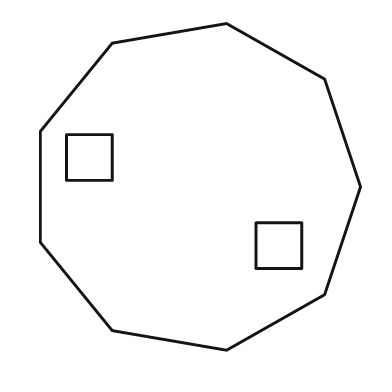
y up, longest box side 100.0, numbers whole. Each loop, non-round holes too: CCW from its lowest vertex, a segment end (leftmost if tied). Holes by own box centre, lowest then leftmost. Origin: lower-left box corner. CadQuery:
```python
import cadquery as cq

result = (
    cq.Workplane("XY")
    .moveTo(57.0, 0.0)
    .lineTo(87.0, 17.0)
    .lineTo(98.0, 50.0)
    .lineTo(87.0, 83.0)
    .lineTo(57.0, 100.0)
    .lineTo(22.0, 94.0)
    .lineTo(0.0, 67.0)
    .lineTo(0.0, 33.0)
    .lineTo(22.0, 6.0)
    .close()
    .moveTo(66.0, 25.0)
    .lineTo(80.0, 25.0)
    .lineTo(80.0, 39.0)
    .lineTo(66.0, 39.0)
    .close()
    .moveTo(8.0, 52.0)
    .lineTo(22.0, 52.0)
    .lineTo(22.0, 66.0)
    .lineTo(8.0, 66.0)
    .close()
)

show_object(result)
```